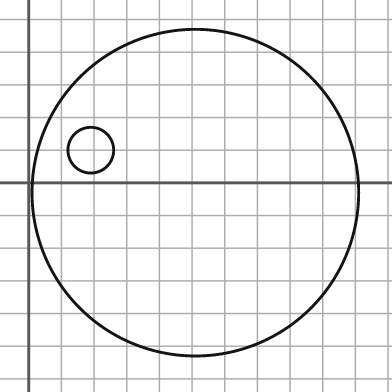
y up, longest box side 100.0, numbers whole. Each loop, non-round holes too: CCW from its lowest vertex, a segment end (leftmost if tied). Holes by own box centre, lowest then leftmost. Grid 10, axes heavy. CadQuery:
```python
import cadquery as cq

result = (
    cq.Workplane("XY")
    .moveTo(51.0, -3.0)
    .circle(50.0)
    .moveTo(19.0, 10.0)
    .circle(7.0)
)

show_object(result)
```